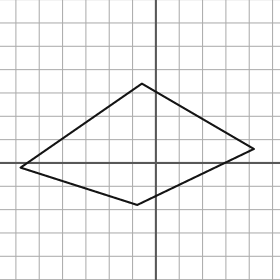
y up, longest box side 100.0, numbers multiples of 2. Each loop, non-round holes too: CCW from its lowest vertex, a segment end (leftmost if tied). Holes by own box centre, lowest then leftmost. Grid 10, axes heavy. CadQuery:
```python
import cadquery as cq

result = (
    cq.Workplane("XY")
    .moveTo(-8.0, -18.0)
    .lineTo(42.0, 6.0)
    .lineTo(-6.0, 34.0)
    .lineTo(-58.0, -2.0)
    .close()
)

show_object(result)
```